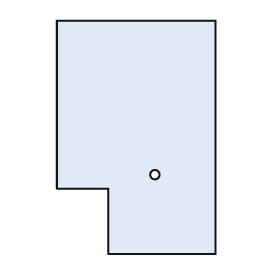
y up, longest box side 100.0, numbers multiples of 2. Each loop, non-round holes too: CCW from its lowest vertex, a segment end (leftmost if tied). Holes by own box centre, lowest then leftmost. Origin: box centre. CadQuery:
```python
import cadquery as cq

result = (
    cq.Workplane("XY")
    .moveTo(-12.0, -50.0)
    .lineTo(34.0, -50.0)
    .lineTo(34.0, 50.0)
    .lineTo(-34.0, 50.0)
    .lineTo(-34.0, -22.0)
    .lineTo(-12.0, -22.0)
    .close()
    .moveTo(8.0, -16.0)
    .circle(2.0)
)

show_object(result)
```